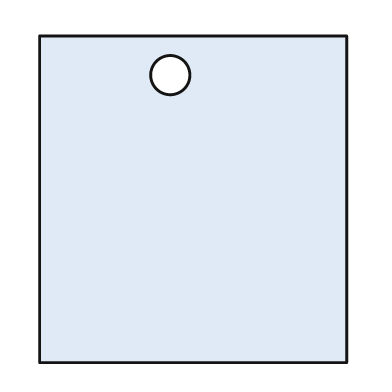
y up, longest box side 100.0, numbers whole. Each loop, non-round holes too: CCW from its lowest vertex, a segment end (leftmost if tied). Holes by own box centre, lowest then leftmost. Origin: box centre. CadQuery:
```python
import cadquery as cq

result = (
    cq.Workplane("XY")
    .moveTo(-47.0, -50.0)
    .lineTo(47.0, -50.0)
    .lineTo(47.0, 50.0)
    .lineTo(-47.0, 50.0)
    .close()
    .moveTo(-7.0, 38.0)
    .circle(6.0)
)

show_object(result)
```